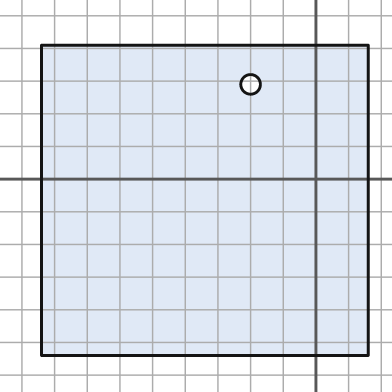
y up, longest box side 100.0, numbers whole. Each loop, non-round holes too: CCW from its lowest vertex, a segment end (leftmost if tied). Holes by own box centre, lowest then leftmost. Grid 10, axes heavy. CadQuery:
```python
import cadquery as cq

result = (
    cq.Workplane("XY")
    .moveTo(-84.0, -54.0)
    .lineTo(16.0, -54.0)
    .lineTo(16.0, 41.0)
    .lineTo(-84.0, 41.0)
    .close()
    .moveTo(-20.0, 29.0)
    .circle(3.0)
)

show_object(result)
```